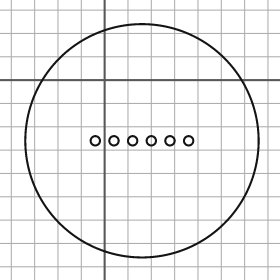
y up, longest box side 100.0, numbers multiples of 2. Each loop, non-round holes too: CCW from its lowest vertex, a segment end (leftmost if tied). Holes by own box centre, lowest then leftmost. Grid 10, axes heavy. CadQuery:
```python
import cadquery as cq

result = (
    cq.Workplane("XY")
    .moveTo(16.0, -26.0)
    .circle(50.0)
    .moveTo(-4.0, -26.0)
    .circle(2.0)
    .moveTo(4.0, -26.0)
    .circle(2.0)
    .moveTo(12.0, -26.0)
    .circle(2.0)
    .moveTo(20.0, -26.0)
    .circle(2.0)
    .moveTo(28.0, -26.0)
    .circle(2.0)
    .moveTo(36.0, -26.0)
    .circle(2.0)
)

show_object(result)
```